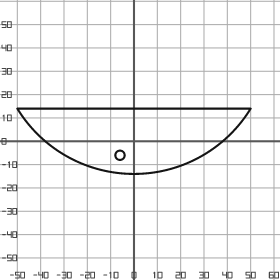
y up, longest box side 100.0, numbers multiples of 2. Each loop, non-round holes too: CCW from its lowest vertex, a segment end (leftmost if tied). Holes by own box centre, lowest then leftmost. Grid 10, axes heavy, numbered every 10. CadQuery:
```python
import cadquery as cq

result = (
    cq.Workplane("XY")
    .moveTo(-50.0, 14.0)
    .threePointArc((0.0, -14.0), (50.0, 14.0))
    .close()
    .moveTo(-6.0, -6.0)
    .circle(2.0)
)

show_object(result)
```